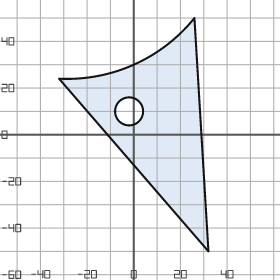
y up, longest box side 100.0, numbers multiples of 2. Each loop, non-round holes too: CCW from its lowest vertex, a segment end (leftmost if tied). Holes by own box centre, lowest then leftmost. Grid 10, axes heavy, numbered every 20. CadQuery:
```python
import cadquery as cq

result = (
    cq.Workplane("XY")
    .moveTo(32.0, -50.0)
    .lineTo(26.0, 50.0)
    .threePointArc((0.0, 30.0), (-32.0, 24.0))
    .close()
    .moveTo(-2.0, 10.0)
    .circle(6.0)
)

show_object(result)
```